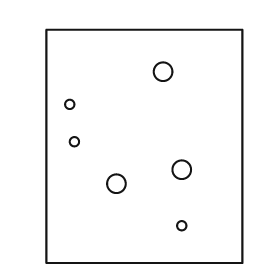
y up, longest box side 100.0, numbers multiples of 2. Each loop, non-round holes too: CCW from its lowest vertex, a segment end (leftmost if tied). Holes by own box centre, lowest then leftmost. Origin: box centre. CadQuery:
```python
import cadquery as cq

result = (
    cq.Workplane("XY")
    .moveTo(-42.0, -50.0)
    .lineTo(42.0, -50.0)
    .lineTo(42.0, 50.0)
    .lineTo(-42.0, 50.0)
    .close()
    .moveTo(16.0, -34.0)
    .circle(2.0)
    .moveTo(-12.0, -16.0)
    .circle(4.0)
    .moveTo(16.0, -10.0)
    .circle(4.0)
    .moveTo(-30.0, 2.0)
    .circle(2.0)
    .moveTo(-32.0, 18.0)
    .circle(2.0)
    .moveTo(8.0, 32.0)
    .circle(4.0)
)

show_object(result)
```